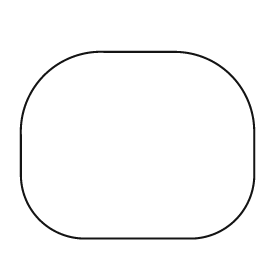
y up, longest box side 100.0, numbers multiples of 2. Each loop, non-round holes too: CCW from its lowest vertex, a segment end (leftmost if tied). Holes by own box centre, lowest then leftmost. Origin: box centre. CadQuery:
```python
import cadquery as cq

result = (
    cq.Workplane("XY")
    .moveTo(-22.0, -40.0)
    .lineTo(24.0, -40.0)
    .threePointArc((42.0, -32.0), (50.0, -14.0))
    .lineTo(50.0, 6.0)
    .threePointArc((40.0, 30.0), (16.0, 40.0))
    .lineTo(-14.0, 40.0)
    .threePointArc((-40.0, 30.0), (-50.0, 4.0))
    .lineTo(-50.0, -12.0)
    .threePointArc((-42.0, -32.0), (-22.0, -40.0))
    .close()
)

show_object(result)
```